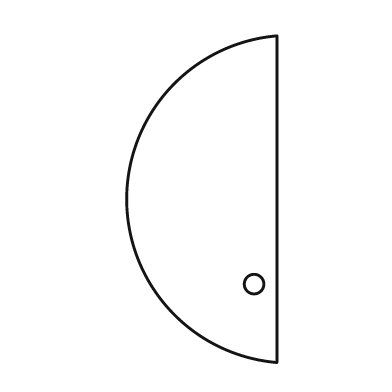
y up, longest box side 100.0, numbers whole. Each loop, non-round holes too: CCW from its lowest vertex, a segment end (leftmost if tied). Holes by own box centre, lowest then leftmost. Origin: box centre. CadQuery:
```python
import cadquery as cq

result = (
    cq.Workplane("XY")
    .moveTo(23.0, -50.0)
    .lineTo(23.0, 50.0)
    .threePointArc((-23.0, 0.0), (23.0, -50.0))
    .close()
    .moveTo(16.0, -26.0)
    .circle(3.0)
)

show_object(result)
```